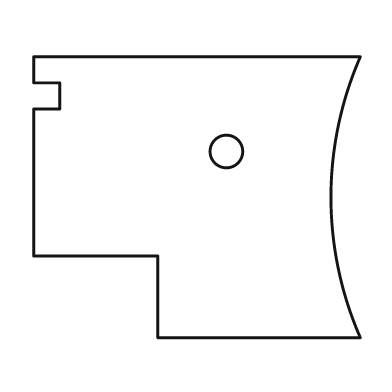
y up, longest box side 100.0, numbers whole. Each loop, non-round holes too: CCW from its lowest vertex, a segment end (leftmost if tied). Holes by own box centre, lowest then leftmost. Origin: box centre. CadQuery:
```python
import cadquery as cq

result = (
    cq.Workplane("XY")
    .moveTo(-12.0, -43.0)
    .lineTo(50.0, -43.0)
    .threePointArc((41.0, 0.0), (50.0, 43.0))
    .lineTo(-50.0, 43.0)
    .lineTo(-50.0, 35.0)
    .lineTo(-42.0, 35.0)
    .lineTo(-42.0, 27.0)
    .lineTo(-50.0, 27.0)
    .lineTo(-50.0, -18.0)
    .lineTo(-12.0, -18.0)
    .close()
    .moveTo(9.0, 14.0)
    .circle(5.0)
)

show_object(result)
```